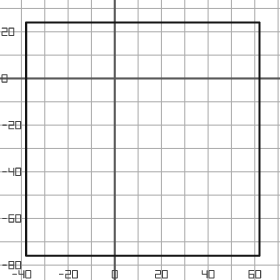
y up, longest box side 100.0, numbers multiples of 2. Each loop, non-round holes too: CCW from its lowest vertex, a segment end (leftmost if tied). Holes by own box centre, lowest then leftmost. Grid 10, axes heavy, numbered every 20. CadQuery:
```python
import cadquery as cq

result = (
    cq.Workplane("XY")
    .moveTo(-38.0, -76.0)
    .lineTo(62.0, -76.0)
    .lineTo(62.0, 24.0)
    .lineTo(-38.0, 24.0)
    .close()
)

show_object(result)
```